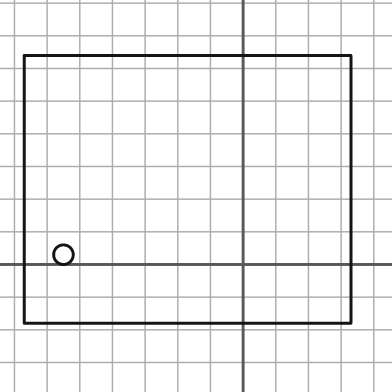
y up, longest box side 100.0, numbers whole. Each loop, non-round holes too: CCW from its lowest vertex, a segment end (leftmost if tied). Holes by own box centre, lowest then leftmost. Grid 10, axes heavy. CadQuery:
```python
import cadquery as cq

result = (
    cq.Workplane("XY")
    .moveTo(-67.0, -18.0)
    .lineTo(33.0, -18.0)
    .lineTo(33.0, 64.0)
    .lineTo(-67.0, 64.0)
    .close()
    .moveTo(-55.0, 3.0)
    .circle(3.0)
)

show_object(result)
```